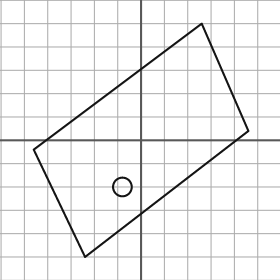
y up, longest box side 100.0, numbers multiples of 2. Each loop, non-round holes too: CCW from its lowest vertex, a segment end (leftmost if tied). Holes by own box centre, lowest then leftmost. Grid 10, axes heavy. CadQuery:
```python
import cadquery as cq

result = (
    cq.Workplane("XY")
    .moveTo(-24.0, -50.0)
    .lineTo(46.0, 4.0)
    .lineTo(26.0, 50.0)
    .lineTo(-46.0, -4.0)
    .close()
    .moveTo(-8.0, -20.0)
    .circle(4.0)
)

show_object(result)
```